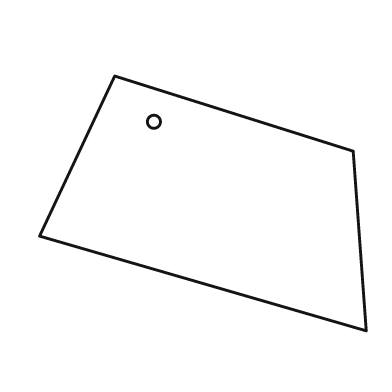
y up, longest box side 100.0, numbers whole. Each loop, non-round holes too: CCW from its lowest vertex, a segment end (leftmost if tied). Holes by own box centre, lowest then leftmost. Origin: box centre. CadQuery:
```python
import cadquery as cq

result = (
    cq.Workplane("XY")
    .moveTo(50.0, -39.0)
    .lineTo(46.0, 16.0)
    .lineTo(-27.0, 39.0)
    .lineTo(-50.0, -10.0)
    .close()
    .moveTo(-15.0, 25.0)
    .circle(2.0)
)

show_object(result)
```